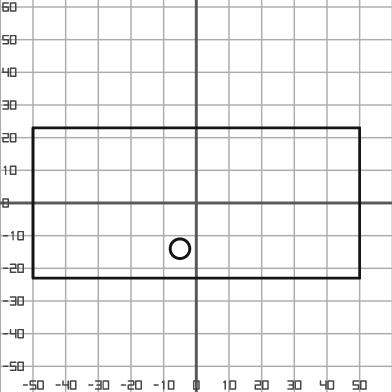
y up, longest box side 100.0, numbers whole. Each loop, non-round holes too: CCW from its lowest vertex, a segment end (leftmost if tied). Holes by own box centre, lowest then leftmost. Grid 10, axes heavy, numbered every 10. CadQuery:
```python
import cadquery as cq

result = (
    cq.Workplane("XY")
    .moveTo(-50.0, -23.0)
    .lineTo(50.0, -23.0)
    .lineTo(50.0, 23.0)
    .lineTo(-50.0, 23.0)
    .close()
    .moveTo(-5.0, -14.0)
    .circle(3.0)
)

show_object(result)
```